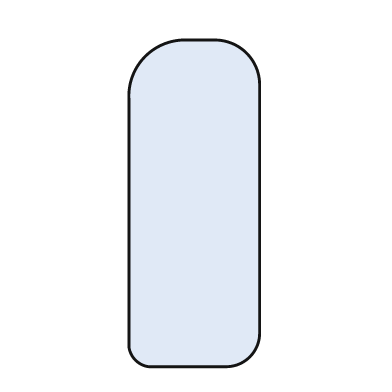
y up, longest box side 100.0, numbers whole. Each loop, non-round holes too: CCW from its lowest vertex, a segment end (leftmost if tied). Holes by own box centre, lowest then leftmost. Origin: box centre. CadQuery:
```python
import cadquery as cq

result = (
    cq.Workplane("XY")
    .moveTo(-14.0, -50.0)
    .lineTo(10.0, -50.0)
    .threePointArc((17.0, -47.0), (20.0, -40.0))
    .lineTo(20.0, 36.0)
    .threePointArc((16.0, 46.0), (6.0, 50.0))
    .lineTo(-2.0, 50.0)
    .threePointArc((-15.0, 45.0), (-20.0, 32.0))
    .lineTo(-20.0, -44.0)
    .threePointArc((-18.0, -48.0), (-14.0, -50.0))
    .close()
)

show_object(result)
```